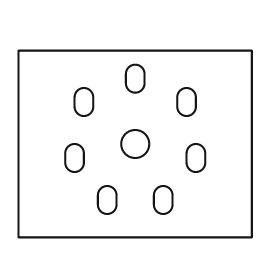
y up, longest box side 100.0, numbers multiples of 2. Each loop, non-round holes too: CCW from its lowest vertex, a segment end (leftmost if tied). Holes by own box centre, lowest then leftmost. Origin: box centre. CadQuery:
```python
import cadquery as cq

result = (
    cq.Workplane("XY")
    .moveTo(-50.0, -40.0)
    .lineTo(50.0, -40.0)
    .lineTo(50.0, 40.0)
    .lineTo(-50.0, 40.0)
    .close()
    .moveTo(-16.0, -26.0)
    .threePointArc((-12.0, -30.0), (-8.0, -26.0))
    .lineTo(-8.0, -22.0)
    .threePointArc((-12.0, -18.0), (-16.0, -22.0))
    .close()
    .moveTo(8.0, -26.0)
    .threePointArc((12.0, -30.0), (16.0, -26.0))
    .lineTo(16.0, -22.0)
    .threePointArc((12.0, -18.0), (8.0, -22.0))
    .close()
    .moveTo(-30.0, -8.0)
    .threePointArc((-26.0, -12.0), (-22.0, -8.0))
    .lineTo(-22.0, -4.0)
    .threePointArc((-26.0, 0.0), (-30.0, -4.0))
    .close()
    .moveTo(22.0, -8.0)
    .threePointArc((26.0, -12.0), (30.0, -8.0))
    .lineTo(30.0, -4.0)
    .threePointArc((26.0, 0.0), (22.0, -4.0))
    .close()
    .moveTo(0.0, 0.0)
    .circle(6.0)
    .moveTo(-26.0, 16.0)
    .threePointArc((-22.0, 12.0), (-18.0, 16.0))
    .lineTo(-18.0, 20.0)
    .threePointArc((-22.0, 24.0), (-26.0, 20.0))
    .close()
    .moveTo(18.0, 16.0)
    .threePointArc((22.0, 12.0), (26.0, 16.0))
    .lineTo(26.0, 20.0)
    .threePointArc((22.0, 24.0), (18.0, 20.0))
    .close()
    .moveTo(-4.0, 26.0)
    .threePointArc((0.0, 22.0), (4.0, 26.0))
    .lineTo(4.0, 30.0)
    .threePointArc((0.0, 34.0), (-4.0, 30.0))
    .close()
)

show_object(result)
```